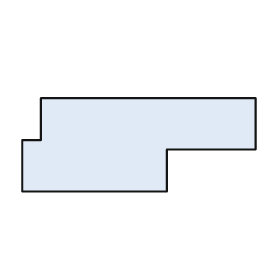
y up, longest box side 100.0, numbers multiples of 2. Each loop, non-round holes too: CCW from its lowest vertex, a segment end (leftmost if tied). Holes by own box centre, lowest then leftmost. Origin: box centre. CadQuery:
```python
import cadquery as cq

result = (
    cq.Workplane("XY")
    .moveTo(-50.0, -20.0)
    .lineTo(12.0, -20.0)
    .lineTo(12.0, -2.0)
    .lineTo(50.0, -2.0)
    .lineTo(50.0, 20.0)
    .lineTo(-42.0, 20.0)
    .lineTo(-42.0, 2.0)
    .lineTo(-50.0, 2.0)
    .close()
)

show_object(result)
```